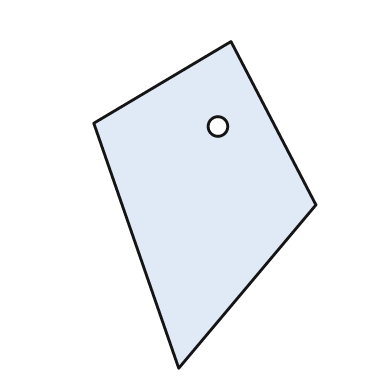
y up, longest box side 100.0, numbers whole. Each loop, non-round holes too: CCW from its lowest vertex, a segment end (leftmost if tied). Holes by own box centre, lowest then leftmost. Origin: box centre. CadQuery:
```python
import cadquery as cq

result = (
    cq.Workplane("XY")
    .moveTo(-8.0, -50.0)
    .lineTo(34.0, 0.0)
    .lineTo(8.0, 50.0)
    .lineTo(-34.0, 25.0)
    .close()
    .moveTo(4.0, 24.0)
    .circle(3.0)
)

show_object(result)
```